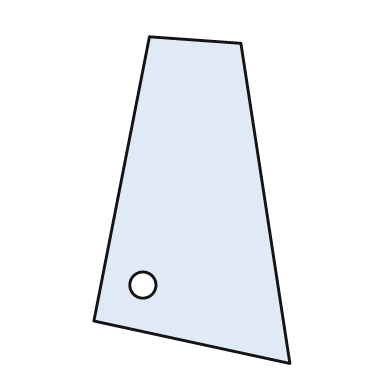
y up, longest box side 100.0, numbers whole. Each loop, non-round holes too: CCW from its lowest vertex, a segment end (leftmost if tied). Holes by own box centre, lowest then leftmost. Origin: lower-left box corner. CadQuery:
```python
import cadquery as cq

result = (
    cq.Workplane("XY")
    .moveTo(60.0, 0.0)
    .lineTo(45.0, 98.0)
    .lineTo(17.0, 100.0)
    .lineTo(0.0, 13.0)
    .close()
    .moveTo(15.0, 24.0)
    .circle(4.0)
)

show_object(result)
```